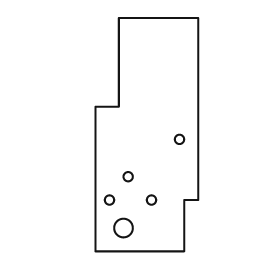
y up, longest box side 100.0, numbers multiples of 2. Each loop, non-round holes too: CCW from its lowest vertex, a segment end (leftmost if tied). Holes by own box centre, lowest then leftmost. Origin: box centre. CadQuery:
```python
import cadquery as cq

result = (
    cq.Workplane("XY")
    .moveTo(-22.0, -50.0)
    .lineTo(16.0, -50.0)
    .lineTo(16.0, -28.0)
    .lineTo(22.0, -28.0)
    .lineTo(22.0, 50.0)
    .lineTo(-12.0, 50.0)
    .lineTo(-12.0, 12.0)
    .lineTo(-22.0, 12.0)
    .close()
    .moveTo(-10.0, -40.0)
    .circle(4.0)
    .moveTo(-16.0, -28.0)
    .circle(2.0)
    .moveTo(2.0, -28.0)
    .circle(2.0)
    .moveTo(-8.0, -18.0)
    .circle(2.0)
    .moveTo(14.0, -2.0)
    .circle(2.0)
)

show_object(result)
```